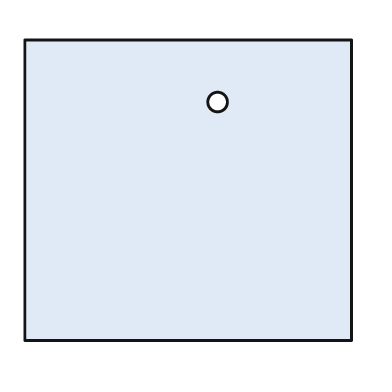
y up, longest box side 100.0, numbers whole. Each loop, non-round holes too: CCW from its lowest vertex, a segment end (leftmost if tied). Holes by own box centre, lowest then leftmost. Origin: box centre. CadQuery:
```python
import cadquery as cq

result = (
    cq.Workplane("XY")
    .moveTo(-50.0, -46.0)
    .lineTo(50.0, -46.0)
    .lineTo(50.0, 46.0)
    .lineTo(-50.0, 46.0)
    .close()
    .moveTo(9.0, 27.0)
    .circle(3.0)
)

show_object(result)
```